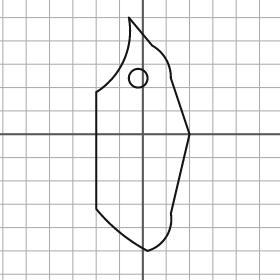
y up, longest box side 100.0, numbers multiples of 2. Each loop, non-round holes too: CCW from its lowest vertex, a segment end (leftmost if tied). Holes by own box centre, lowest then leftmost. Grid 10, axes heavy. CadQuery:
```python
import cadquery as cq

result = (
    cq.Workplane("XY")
    .moveTo(2.0, -50.0)
    .threePointArc((10.0, -44.0), (12.0, -34.0))
    .lineTo(20.0, 0.0)
    .lineTo(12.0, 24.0)
    .threePointArc((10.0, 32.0), (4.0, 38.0))
    .lineTo(-6.0, 50.0)
    .threePointArc((-8.0, 32.0), (-20.0, 18.0))
    .lineTo(-20.0, -32.0)
    .threePointArc((-10.0, -42.0), (2.0, -50.0))
    .close()
    .moveTo(-2.0, 24.0)
    .circle(4.0)
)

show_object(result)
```